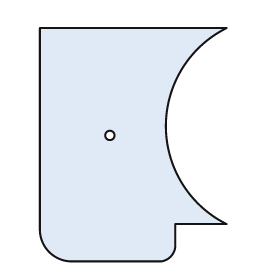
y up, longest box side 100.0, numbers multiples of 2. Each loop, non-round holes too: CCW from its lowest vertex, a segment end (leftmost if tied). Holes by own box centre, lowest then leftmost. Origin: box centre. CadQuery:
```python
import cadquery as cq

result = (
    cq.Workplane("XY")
    .moveTo(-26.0, -50.0)
    .lineTo(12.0, -50.0)
    .threePointArc((16.0, -48.0), (18.0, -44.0))
    .lineTo(18.0, -34.0)
    .lineTo(40.0, -34.0)
    .threePointArc((14.0, 8.0), (40.0, 50.0))
    .lineTo(-40.0, 50.0)
    .lineTo(-40.0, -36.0)
    .threePointArc((-36.0, -46.0), (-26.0, -50.0))
    .close()
    .moveTo(-10.0, 4.0)
    .circle(2.0)
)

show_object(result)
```